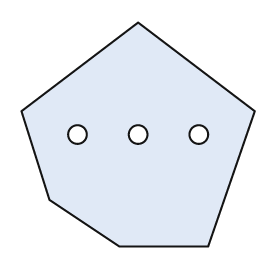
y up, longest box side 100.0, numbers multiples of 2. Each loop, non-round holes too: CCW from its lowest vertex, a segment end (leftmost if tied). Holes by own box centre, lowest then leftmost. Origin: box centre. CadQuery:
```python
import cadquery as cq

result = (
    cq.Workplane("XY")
    .moveTo(-8.0, -48.0)
    .lineTo(30.0, -48.0)
    .lineTo(50.0, 10.0)
    .lineTo(0.0, 48.0)
    .lineTo(-50.0, 10.0)
    .lineTo(-38.0, -28.0)
    .close()
    .moveTo(-26.0, 0.0)
    .circle(4.0)
    .moveTo(0.0, 0.0)
    .circle(4.0)
    .moveTo(26.0, 0.0)
    .circle(4.0)
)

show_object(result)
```